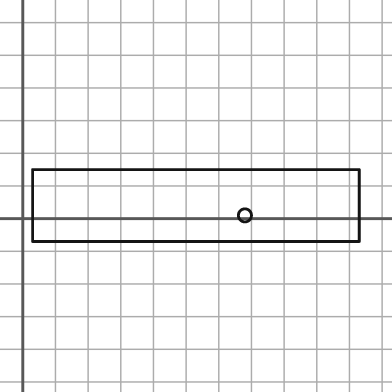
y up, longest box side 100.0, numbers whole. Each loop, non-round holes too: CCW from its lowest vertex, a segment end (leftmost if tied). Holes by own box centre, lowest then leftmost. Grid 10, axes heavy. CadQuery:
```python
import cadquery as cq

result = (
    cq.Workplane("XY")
    .moveTo(3.0, -7.0)
    .lineTo(103.0, -7.0)
    .lineTo(103.0, 15.0)
    .lineTo(3.0, 15.0)
    .close()
    .moveTo(68.0, 1.0)
    .circle(2.0)
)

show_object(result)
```